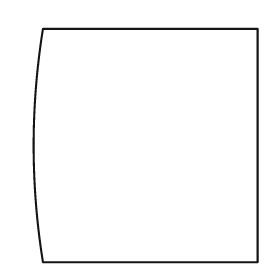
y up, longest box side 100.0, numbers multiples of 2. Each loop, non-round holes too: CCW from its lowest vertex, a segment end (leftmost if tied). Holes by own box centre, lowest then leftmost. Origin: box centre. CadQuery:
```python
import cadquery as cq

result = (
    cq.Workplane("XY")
    .moveTo(-44.0, -50.0)
    .lineTo(48.0, -50.0)
    .lineTo(48.0, 50.0)
    .lineTo(-44.0, 50.0)
    .threePointArc((-48.0, 0.0), (-44.0, -50.0))
    .close()
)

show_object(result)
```